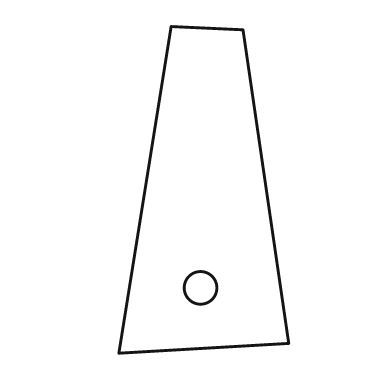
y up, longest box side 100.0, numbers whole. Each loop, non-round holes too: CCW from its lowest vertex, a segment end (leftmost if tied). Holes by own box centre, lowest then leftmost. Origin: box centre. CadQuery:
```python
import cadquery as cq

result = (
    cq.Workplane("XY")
    .moveTo(-26.0, -50.0)
    .lineTo(26.0, -47.0)
    .lineTo(12.0, 49.0)
    .lineTo(-10.0, 50.0)
    .close()
    .moveTo(-1.0, -30.0)
    .circle(5.0)
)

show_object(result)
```